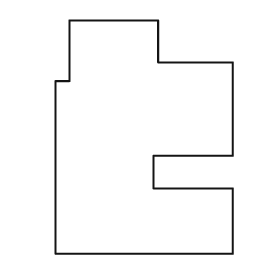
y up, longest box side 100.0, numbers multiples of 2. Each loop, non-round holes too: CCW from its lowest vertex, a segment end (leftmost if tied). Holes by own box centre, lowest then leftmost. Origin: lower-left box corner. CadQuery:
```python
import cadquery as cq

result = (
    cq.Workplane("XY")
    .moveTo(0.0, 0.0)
    .lineTo(76.0, 0.0)
    .lineTo(76.0, 28.0)
    .lineTo(42.0, 28.0)
    .lineTo(42.0, 42.0)
    .lineTo(76.0, 42.0)
    .lineTo(76.0, 82.0)
    .lineTo(44.0, 82.0)
    .lineTo(44.0, 100.0)
    .lineTo(6.0, 100.0)
    .lineTo(6.0, 74.0)
    .lineTo(0.0, 74.0)
    .close()
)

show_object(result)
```